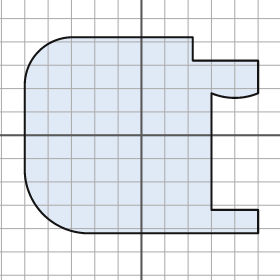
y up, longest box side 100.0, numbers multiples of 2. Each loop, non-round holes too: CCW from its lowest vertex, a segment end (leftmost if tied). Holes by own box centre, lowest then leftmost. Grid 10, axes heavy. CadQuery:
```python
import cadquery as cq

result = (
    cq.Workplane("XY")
    .moveTo(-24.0, -42.0)
    .lineTo(50.0, -42.0)
    .lineTo(50.0, -32.0)
    .lineTo(30.0, -32.0)
    .lineTo(30.0, 18.0)
    .threePointArc((40.0, 16.0), (50.0, 18.0))
    .lineTo(50.0, 32.0)
    .lineTo(22.0, 32.0)
    .lineTo(22.0, 42.0)
    .lineTo(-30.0, 42.0)
    .threePointArc((-44.0, 36.0), (-50.0, 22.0))
    .lineTo(-50.0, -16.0)
    .threePointArc((-42.0, -34.0), (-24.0, -42.0))
    .close()
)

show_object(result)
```